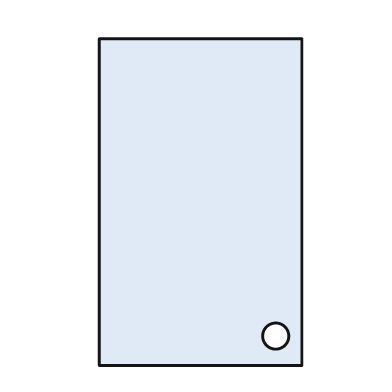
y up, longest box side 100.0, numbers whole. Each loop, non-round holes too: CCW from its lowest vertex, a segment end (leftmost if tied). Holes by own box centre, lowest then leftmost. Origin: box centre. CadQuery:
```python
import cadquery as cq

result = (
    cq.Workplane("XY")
    .moveTo(-31.0, -50.0)
    .lineTo(31.0, -50.0)
    .lineTo(31.0, 50.0)
    .lineTo(-31.0, 50.0)
    .close()
    .moveTo(23.0, -41.0)
    .circle(4.0)
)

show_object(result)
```